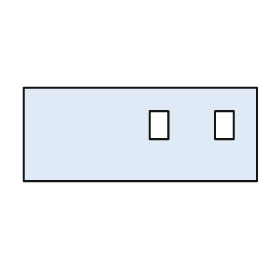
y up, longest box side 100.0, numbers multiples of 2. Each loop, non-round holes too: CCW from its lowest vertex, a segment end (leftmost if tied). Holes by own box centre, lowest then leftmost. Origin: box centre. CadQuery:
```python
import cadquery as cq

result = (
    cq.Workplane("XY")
    .moveTo(-50.0, -20.0)
    .lineTo(50.0, -20.0)
    .lineTo(50.0, 20.0)
    .lineTo(-50.0, 20.0)
    .close()
    .moveTo(4.0, -2.0)
    .lineTo(12.0, -2.0)
    .lineTo(12.0, 10.0)
    .lineTo(4.0, 10.0)
    .close()
    .moveTo(32.0, -2.0)
    .lineTo(40.0, -2.0)
    .lineTo(40.0, 10.0)
    .lineTo(32.0, 10.0)
    .close()
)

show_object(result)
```